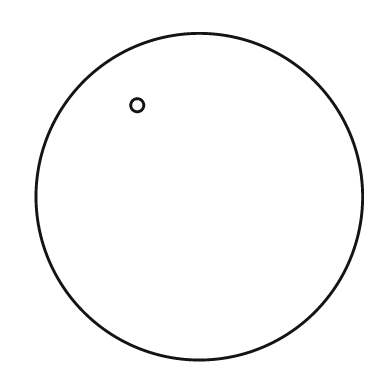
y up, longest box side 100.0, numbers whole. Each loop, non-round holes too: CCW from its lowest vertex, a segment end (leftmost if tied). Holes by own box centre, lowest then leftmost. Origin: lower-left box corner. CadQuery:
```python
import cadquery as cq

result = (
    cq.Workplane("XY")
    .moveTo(50.0, 50.0)
    .circle(50.0)
    .moveTo(31.0, 78.0)
    .circle(2.0)
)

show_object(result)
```